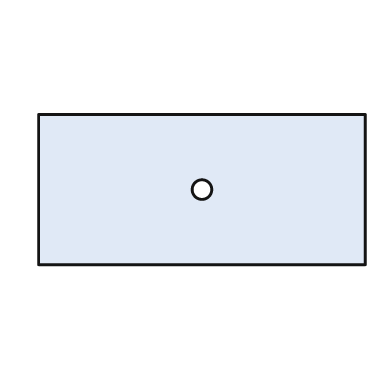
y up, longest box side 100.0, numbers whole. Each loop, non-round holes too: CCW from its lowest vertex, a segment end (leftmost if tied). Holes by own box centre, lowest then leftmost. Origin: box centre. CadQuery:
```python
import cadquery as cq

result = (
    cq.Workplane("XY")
    .moveTo(-50.0, -23.0)
    .lineTo(50.0, -23.0)
    .lineTo(50.0, 23.0)
    .lineTo(-50.0, 23.0)
    .close()
    .moveTo(0.0, 0.0)
    .circle(3.0)
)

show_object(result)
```